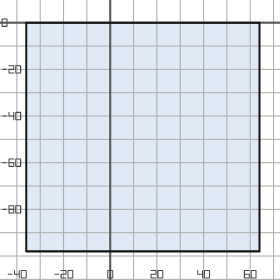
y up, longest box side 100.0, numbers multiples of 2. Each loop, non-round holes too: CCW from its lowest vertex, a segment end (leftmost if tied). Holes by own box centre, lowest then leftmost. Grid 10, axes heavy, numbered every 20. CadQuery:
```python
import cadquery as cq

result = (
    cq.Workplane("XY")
    .moveTo(-36.0, -98.0)
    .lineTo(64.0, -98.0)
    .lineTo(64.0, 0.0)
    .lineTo(-36.0, 0.0)
    .close()
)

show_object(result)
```